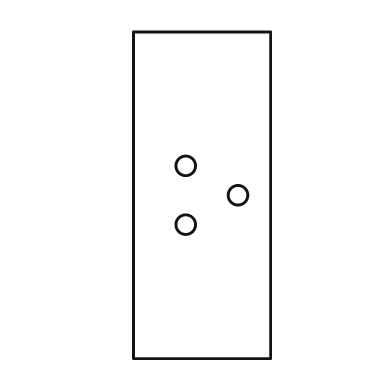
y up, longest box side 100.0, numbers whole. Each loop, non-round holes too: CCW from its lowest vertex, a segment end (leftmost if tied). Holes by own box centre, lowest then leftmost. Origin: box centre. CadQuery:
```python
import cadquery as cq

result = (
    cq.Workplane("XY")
    .moveTo(-21.0, -50.0)
    .lineTo(21.0, -50.0)
    .lineTo(21.0, 50.0)
    .lineTo(-21.0, 50.0)
    .close()
    .moveTo(-5.0, -9.0)
    .circle(3.0)
    .moveTo(11.0, 0.0)
    .circle(3.0)
    .moveTo(-5.0, 9.0)
    .circle(3.0)
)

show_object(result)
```